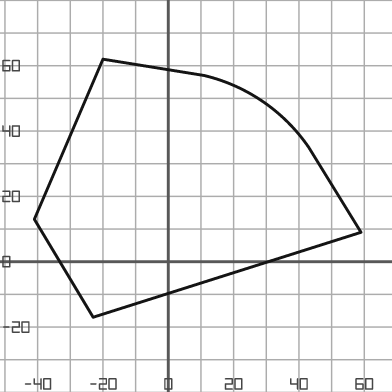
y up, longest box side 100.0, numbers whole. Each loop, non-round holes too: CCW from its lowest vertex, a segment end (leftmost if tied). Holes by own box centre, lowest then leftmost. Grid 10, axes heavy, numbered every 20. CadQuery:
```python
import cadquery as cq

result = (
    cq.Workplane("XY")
    .moveTo(-23.0, -17.0)
    .lineTo(59.0, 9.0)
    .lineTo(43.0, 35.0)
    .threePointArc((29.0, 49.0), (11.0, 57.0))
    .lineTo(-20.0, 62.0)
    .lineTo(-41.0, 13.0)
    .close()
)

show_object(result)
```